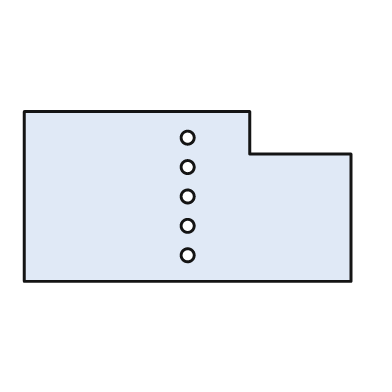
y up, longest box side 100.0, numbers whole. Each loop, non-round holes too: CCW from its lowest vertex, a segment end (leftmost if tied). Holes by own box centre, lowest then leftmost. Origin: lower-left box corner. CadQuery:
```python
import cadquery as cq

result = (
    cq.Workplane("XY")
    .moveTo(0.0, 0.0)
    .lineTo(100.0, 0.0)
    .lineTo(100.0, 39.0)
    .lineTo(69.0, 39.0)
    .lineTo(69.0, 52.0)
    .lineTo(0.0, 52.0)
    .close()
    .moveTo(50.0, 8.0)
    .circle(2.0)
    .moveTo(50.0, 17.0)
    .circle(2.0)
    .moveTo(50.0, 26.0)
    .circle(2.0)
    .moveTo(50.0, 35.0)
    .circle(2.0)
    .moveTo(50.0, 44.0)
    .circle(2.0)
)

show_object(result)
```